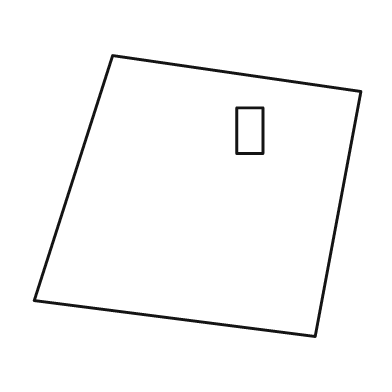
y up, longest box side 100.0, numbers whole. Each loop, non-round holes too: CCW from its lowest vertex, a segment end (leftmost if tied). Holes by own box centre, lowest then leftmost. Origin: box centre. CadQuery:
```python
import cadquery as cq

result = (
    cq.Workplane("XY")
    .moveTo(36.0, -43.0)
    .lineTo(50.0, 32.0)
    .lineTo(-26.0, 43.0)
    .lineTo(-50.0, -32.0)
    .close()
    .moveTo(12.0, 13.0)
    .lineTo(20.0, 13.0)
    .lineTo(20.0, 27.0)
    .lineTo(12.0, 27.0)
    .close()
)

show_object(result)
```